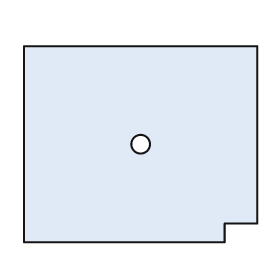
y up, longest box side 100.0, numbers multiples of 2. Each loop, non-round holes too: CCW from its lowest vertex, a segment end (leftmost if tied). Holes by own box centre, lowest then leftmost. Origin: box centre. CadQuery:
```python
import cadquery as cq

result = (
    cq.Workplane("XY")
    .moveTo(-50.0, -42.0)
    .lineTo(36.0, -42.0)
    .lineTo(36.0, -34.0)
    .lineTo(50.0, -34.0)
    .lineTo(50.0, 42.0)
    .lineTo(-50.0, 42.0)
    .close()
    .moveTo(0.0, 0.0)
    .circle(4.0)
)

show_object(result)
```